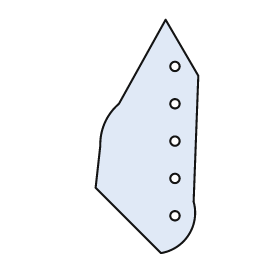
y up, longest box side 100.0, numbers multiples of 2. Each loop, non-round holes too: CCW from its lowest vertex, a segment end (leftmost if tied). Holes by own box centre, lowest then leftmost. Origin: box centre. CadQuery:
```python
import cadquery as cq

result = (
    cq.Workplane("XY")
    .moveTo(6.0, -50.0)
    .threePointArc((18.0, -42.0), (20.0, -28.0))
    .lineTo(22.0, 26.0)
    .lineTo(8.0, 50.0)
    .lineTo(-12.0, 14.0)
    .threePointArc((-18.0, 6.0), (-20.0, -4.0))
    .lineTo(-22.0, -22.0)
    .close()
    .moveTo(12.0, -34.0)
    .circle(2.0)
    .moveTo(12.0, -18.0)
    .circle(2.0)
    .moveTo(12.0, -2.0)
    .circle(2.0)
    .moveTo(12.0, 14.0)
    .circle(2.0)
    .moveTo(12.0, 30.0)
    .circle(2.0)
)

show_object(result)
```